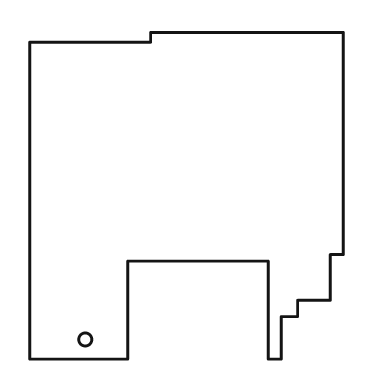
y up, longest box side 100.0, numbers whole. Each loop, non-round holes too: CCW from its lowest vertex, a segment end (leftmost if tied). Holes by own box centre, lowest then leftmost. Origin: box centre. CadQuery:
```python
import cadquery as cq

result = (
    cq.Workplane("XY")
    .moveTo(-48.0, -50.0)
    .lineTo(-18.0, -50.0)
    .lineTo(-18.0, -20.0)
    .lineTo(25.0, -20.0)
    .lineTo(25.0, -50.0)
    .lineTo(29.0, -50.0)
    .lineTo(29.0, -37.0)
    .lineTo(34.0, -37.0)
    .lineTo(34.0, -32.0)
    .lineTo(44.0, -32.0)
    .lineTo(44.0, -18.0)
    .lineTo(48.0, -18.0)
    .lineTo(48.0, 50.0)
    .lineTo(-11.0, 50.0)
    .lineTo(-11.0, 47.0)
    .lineTo(-48.0, 47.0)
    .close()
    .moveTo(-31.0, -44.0)
    .circle(2.0)
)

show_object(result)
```